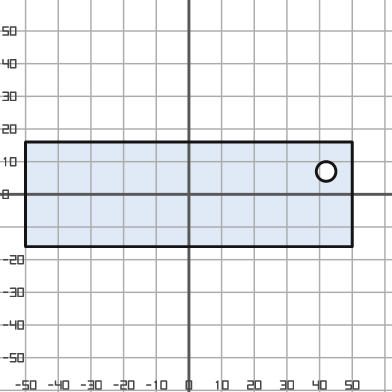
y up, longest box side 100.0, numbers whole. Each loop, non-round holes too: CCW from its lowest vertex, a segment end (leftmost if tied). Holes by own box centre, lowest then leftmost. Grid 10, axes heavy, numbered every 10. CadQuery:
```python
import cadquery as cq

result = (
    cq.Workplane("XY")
    .moveTo(-50.0, -16.0)
    .lineTo(50.0, -16.0)
    .lineTo(50.0, 16.0)
    .lineTo(-50.0, 16.0)
    .close()
    .moveTo(42.0, 7.0)
    .circle(3.0)
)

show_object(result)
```